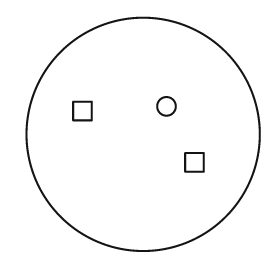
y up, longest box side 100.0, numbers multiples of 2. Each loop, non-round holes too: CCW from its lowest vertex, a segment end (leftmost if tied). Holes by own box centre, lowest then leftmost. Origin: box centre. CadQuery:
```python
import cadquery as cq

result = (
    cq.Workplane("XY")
    .moveTo(0.0, 0.0)
    .circle(50.0)
    .moveTo(18.0, -16.0)
    .lineTo(26.0, -16.0)
    .lineTo(26.0, -8.0)
    .lineTo(18.0, -8.0)
    .close()
    .moveTo(-30.0, 6.0)
    .lineTo(-22.0, 6.0)
    .lineTo(-22.0, 14.0)
    .lineTo(-30.0, 14.0)
    .close()
    .moveTo(10.0, 12.0)
    .circle(4.0)
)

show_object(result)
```